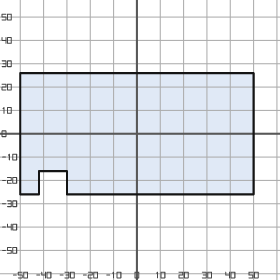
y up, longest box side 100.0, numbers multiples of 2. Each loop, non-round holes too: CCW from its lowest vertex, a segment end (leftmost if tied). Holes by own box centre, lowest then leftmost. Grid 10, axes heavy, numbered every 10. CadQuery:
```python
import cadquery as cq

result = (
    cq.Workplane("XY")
    .moveTo(-50.0, -26.0)
    .lineTo(-42.0, -26.0)
    .lineTo(-42.0, -16.0)
    .lineTo(-30.0, -16.0)
    .lineTo(-30.0, -26.0)
    .lineTo(50.0, -26.0)
    .lineTo(50.0, 26.0)
    .lineTo(-50.0, 26.0)
    .close()
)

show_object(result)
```